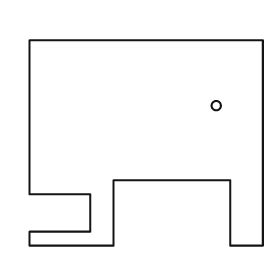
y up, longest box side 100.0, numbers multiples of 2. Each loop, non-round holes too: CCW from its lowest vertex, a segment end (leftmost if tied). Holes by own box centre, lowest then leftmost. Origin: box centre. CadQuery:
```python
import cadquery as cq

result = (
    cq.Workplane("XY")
    .moveTo(-50.0, -44.0)
    .lineTo(-14.0, -44.0)
    .lineTo(-14.0, -16.0)
    .lineTo(36.0, -16.0)
    .lineTo(36.0, -44.0)
    .lineTo(50.0, -44.0)
    .lineTo(50.0, 44.0)
    .lineTo(-50.0, 44.0)
    .lineTo(-50.0, -22.0)
    .lineTo(-24.0, -22.0)
    .lineTo(-24.0, -38.0)
    .lineTo(-50.0, -38.0)
    .close()
    .moveTo(30.0, 16.0)
    .circle(2.0)
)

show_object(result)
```